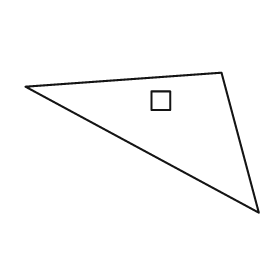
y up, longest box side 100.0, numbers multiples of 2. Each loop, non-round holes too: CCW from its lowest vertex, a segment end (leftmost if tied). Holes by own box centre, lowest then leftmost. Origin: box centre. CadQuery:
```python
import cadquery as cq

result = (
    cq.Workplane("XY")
    .moveTo(50.0, -30.0)
    .lineTo(34.0, 30.0)
    .lineTo(-50.0, 24.0)
    .close()
    .moveTo(4.0, 14.0)
    .lineTo(12.0, 14.0)
    .lineTo(12.0, 22.0)
    .lineTo(4.0, 22.0)
    .close()
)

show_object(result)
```